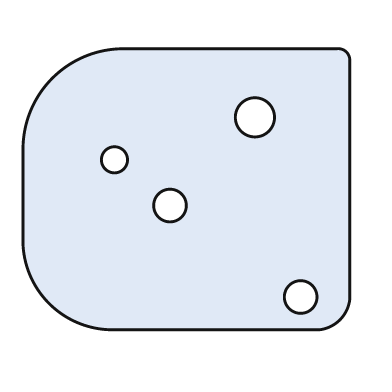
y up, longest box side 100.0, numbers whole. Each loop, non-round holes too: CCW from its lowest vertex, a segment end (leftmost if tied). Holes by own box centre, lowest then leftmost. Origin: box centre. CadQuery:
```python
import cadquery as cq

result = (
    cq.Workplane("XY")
    .moveTo(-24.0, -43.0)
    .lineTo(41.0, -43.0)
    .threePointArc((47.0, -40.0), (50.0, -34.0))
    .lineTo(50.0, 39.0)
    .threePointArc((49.0, 42.0), (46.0, 43.0))
    .lineTo(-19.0, 43.0)
    .threePointArc((-41.0, 34.0), (-50.0, 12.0))
    .lineTo(-50.0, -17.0)
    .threePointArc((-42.0, -35.0), (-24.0, -43.0))
    .close()
    .moveTo(35.0, -33.0)
    .circle(5.0)
    .moveTo(-5.0, -5.0)
    .circle(5.0)
    .moveTo(-22.0, 9.0)
    .circle(4.0)
    .moveTo(21.0, 22.0)
    .circle(6.0)
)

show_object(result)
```